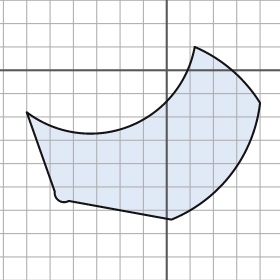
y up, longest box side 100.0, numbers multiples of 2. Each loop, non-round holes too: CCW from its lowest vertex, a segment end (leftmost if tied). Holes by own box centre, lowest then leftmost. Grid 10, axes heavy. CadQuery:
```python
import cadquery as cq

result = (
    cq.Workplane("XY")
    .moveTo(2.0, -64.0)
    .threePointArc((28.0, -44.0), (40.0, -14.0))
    .threePointArc((28.0, 0.0), (12.0, 10.0))
    .threePointArc((-16.0, -24.0), (-60.0, -18.0))
    .lineTo(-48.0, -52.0)
    .threePointArc((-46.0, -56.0), (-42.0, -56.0))
    .close()
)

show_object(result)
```